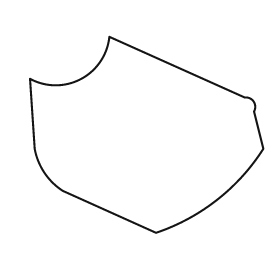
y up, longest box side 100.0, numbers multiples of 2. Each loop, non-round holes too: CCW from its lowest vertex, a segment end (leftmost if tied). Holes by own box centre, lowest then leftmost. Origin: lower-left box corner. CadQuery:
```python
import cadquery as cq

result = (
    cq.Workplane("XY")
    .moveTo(54.0, 0.0)
    .threePointArc((80.0, 14.0), (100.0, 36.0))
    .lineTo(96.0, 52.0)
    .threePointArc((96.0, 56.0), (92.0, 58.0))
    .lineTo(34.0, 84.0)
    .threePointArc((22.0, 66.0), (0.0, 66.0))
    .lineTo(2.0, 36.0)
    .threePointArc((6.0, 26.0), (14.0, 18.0))
    .close()
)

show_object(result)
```